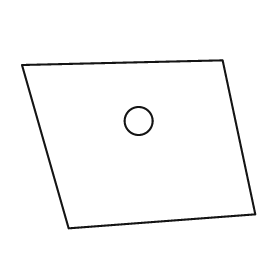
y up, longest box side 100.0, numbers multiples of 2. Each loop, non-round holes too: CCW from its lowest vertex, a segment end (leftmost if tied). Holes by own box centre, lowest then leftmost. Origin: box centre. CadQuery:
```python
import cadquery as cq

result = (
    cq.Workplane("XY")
    .moveTo(-30.0, -36.0)
    .lineTo(50.0, -30.0)
    .lineTo(36.0, 36.0)
    .lineTo(-50.0, 34.0)
    .close()
    .moveTo(0.0, 10.0)
    .circle(6.0)
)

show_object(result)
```